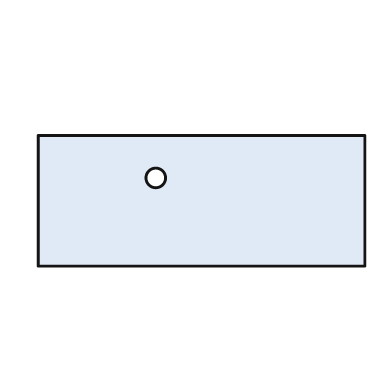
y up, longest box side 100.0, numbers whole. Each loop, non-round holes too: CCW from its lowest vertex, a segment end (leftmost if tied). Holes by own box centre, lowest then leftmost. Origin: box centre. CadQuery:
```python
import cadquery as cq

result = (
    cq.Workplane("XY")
    .moveTo(-50.0, -20.0)
    .lineTo(50.0, -20.0)
    .lineTo(50.0, 20.0)
    .lineTo(-50.0, 20.0)
    .close()
    .moveTo(-14.0, 7.0)
    .circle(3.0)
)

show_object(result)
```